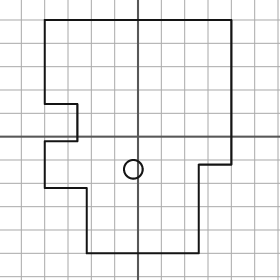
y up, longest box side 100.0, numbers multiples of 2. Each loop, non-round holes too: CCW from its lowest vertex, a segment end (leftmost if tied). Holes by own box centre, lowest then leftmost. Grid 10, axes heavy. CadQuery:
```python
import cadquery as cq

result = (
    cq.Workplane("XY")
    .moveTo(-22.0, -50.0)
    .lineTo(26.0, -50.0)
    .lineTo(26.0, -12.0)
    .lineTo(40.0, -12.0)
    .lineTo(40.0, 50.0)
    .lineTo(-40.0, 50.0)
    .lineTo(-40.0, 14.0)
    .lineTo(-26.0, 14.0)
    .lineTo(-26.0, -2.0)
    .lineTo(-40.0, -2.0)
    .lineTo(-40.0, -22.0)
    .lineTo(-22.0, -22.0)
    .close()
    .moveTo(-2.0, -14.0)
    .circle(4.0)
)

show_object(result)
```